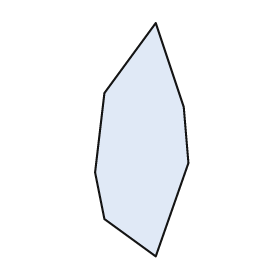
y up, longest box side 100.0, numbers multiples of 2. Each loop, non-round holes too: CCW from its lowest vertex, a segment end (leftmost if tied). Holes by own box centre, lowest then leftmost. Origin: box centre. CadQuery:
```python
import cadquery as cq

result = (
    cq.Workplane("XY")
    .moveTo(6.0, -50.0)
    .lineTo(20.0, -10.0)
    .lineTo(18.0, 14.0)
    .lineTo(6.0, 50.0)
    .lineTo(-16.0, 20.0)
    .lineTo(-20.0, -14.0)
    .lineTo(-16.0, -34.0)
    .close()
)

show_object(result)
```